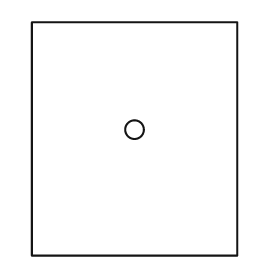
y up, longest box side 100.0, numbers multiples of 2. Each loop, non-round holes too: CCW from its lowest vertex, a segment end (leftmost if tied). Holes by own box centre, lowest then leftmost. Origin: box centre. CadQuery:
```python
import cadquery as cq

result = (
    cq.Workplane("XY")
    .moveTo(-44.0, -50.0)
    .lineTo(44.0, -50.0)
    .lineTo(44.0, 50.0)
    .lineTo(-44.0, 50.0)
    .close()
    .moveTo(0.0, 4.0)
    .circle(4.0)
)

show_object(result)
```